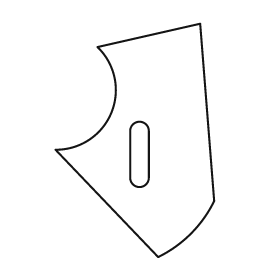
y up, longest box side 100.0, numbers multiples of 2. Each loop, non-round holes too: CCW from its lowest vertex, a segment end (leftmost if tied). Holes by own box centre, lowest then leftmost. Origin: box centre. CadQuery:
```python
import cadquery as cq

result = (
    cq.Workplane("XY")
    .moveTo(10.0, -50.0)
    .threePointArc((24.0, -40.0), (34.0, -26.0))
    .lineTo(28.0, 50.0)
    .lineTo(-16.0, 40.0)
    .threePointArc((-10.0, 12.0), (-34.0, -4.0))
    .close()
    .moveTo(-2.0, -16.0)
    .threePointArc((2.0, -20.0), (6.0, -16.0))
    .lineTo(6.0, 4.0)
    .threePointArc((2.0, 8.0), (-2.0, 4.0))
    .close()
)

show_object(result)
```